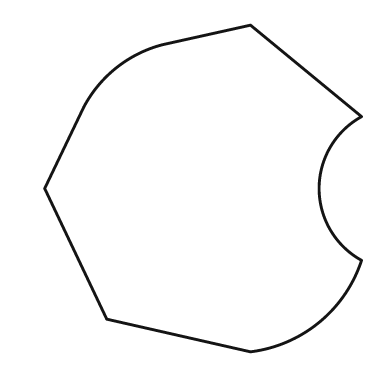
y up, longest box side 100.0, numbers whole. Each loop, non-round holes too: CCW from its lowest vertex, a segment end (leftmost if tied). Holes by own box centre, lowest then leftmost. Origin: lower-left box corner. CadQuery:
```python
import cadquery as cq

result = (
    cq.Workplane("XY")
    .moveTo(63.0, 0.0)
    .threePointArc((84.0, 9.0), (97.0, 28.0))
    .threePointArc((84.0, 50.0), (97.0, 72.0))
    .lineTo(63.0, 100.0)
    .lineTo(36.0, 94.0)
    .threePointArc((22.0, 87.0), (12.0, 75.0))
    .lineTo(0.0, 50.0)
    .lineTo(19.0, 10.0)
    .close()
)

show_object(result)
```